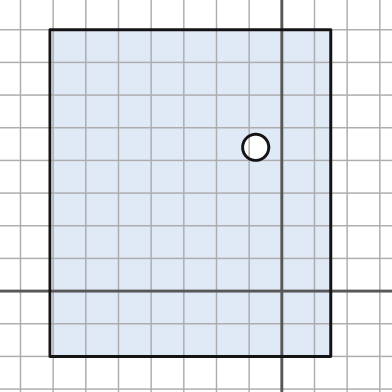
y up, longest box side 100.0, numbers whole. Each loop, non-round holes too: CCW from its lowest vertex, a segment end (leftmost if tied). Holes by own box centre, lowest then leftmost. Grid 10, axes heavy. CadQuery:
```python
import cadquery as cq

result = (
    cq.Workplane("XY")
    .moveTo(-71.0, -20.0)
    .lineTo(15.0, -20.0)
    .lineTo(15.0, 80.0)
    .lineTo(-71.0, 80.0)
    .close()
    .moveTo(-8.0, 44.0)
    .circle(4.0)
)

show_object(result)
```